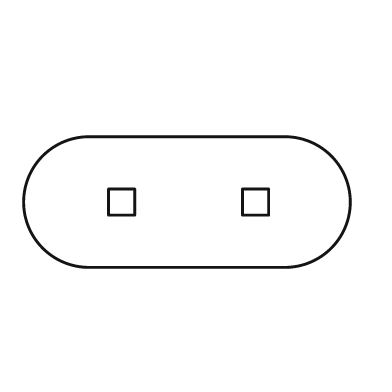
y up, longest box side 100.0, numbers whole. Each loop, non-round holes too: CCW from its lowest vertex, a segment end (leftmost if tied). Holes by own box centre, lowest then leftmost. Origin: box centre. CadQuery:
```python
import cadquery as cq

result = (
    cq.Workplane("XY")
    .moveTo(-30.0, -20.0)
    .lineTo(30.0, -20.0)
    .threePointArc((50.0, 0.0), (30.0, 20.0))
    .lineTo(-30.0, 20.0)
    .threePointArc((-50.0, 0.0), (-30.0, -20.0))
    .close()
    .moveTo(-24.0, -4.0)
    .lineTo(-16.0, -4.0)
    .lineTo(-16.0, 4.0)
    .lineTo(-24.0, 4.0)
    .close()
    .moveTo(17.0, -4.0)
    .lineTo(25.0, -4.0)
    .lineTo(25.0, 4.0)
    .lineTo(17.0, 4.0)
    .close()
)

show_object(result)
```